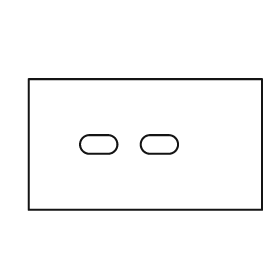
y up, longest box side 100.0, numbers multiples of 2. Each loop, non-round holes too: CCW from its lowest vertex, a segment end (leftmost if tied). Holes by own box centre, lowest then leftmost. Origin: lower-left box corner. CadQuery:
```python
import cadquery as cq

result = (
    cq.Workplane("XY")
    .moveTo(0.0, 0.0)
    .lineTo(100.0, 0.0)
    .lineTo(100.0, 56.0)
    .lineTo(0.0, 56.0)
    .close()
    .moveTo(26.0, 24.0)
    .lineTo(34.0, 24.0)
    .threePointArc((38.0, 28.0), (34.0, 32.0))
    .lineTo(26.0, 32.0)
    .threePointArc((22.0, 28.0), (26.0, 24.0))
    .close()
    .moveTo(52.0, 24.0)
    .lineTo(60.0, 24.0)
    .threePointArc((64.0, 28.0), (60.0, 32.0))
    .lineTo(52.0, 32.0)
    .threePointArc((48.0, 28.0), (52.0, 24.0))
    .close()
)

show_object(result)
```